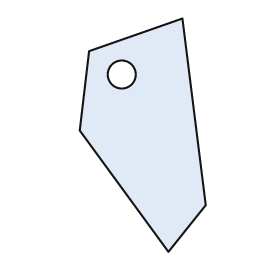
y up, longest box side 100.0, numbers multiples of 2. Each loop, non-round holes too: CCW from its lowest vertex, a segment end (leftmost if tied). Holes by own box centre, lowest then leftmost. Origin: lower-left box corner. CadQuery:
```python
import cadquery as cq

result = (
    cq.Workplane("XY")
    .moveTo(38.0, 0.0)
    .lineTo(54.0, 20.0)
    .lineTo(44.0, 100.0)
    .lineTo(4.0, 86.0)
    .lineTo(0.0, 52.0)
    .close()
    .moveTo(18.0, 76.0)
    .circle(6.0)
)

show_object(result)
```